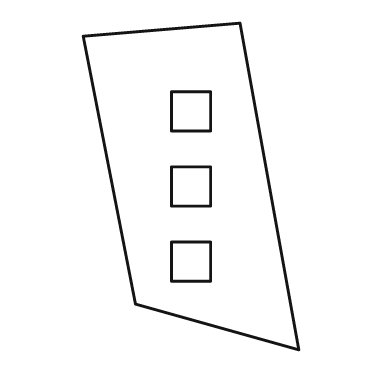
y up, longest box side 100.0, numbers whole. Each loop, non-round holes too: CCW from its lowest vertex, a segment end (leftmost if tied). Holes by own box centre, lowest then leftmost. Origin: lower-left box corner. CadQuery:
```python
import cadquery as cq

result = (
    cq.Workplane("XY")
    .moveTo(66.0, 0.0)
    .lineTo(48.0, 100.0)
    .lineTo(0.0, 96.0)
    .lineTo(16.0, 14.0)
    .close()
    .moveTo(27.0, 21.0)
    .lineTo(39.0, 21.0)
    .lineTo(39.0, 33.0)
    .lineTo(27.0, 33.0)
    .close()
    .moveTo(27.0, 44.0)
    .lineTo(39.0, 44.0)
    .lineTo(39.0, 56.0)
    .lineTo(27.0, 56.0)
    .close()
    .moveTo(27.0, 67.0)
    .lineTo(39.0, 67.0)
    .lineTo(39.0, 79.0)
    .lineTo(27.0, 79.0)
    .close()
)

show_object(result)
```